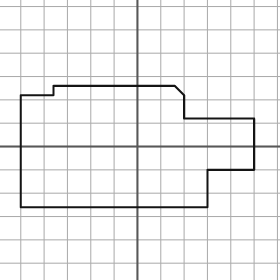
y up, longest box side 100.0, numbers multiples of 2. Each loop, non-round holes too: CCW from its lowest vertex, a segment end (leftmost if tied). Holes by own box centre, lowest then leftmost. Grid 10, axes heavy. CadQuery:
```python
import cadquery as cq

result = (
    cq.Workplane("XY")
    .moveTo(-50.0, -26.0)
    .lineTo(30.0, -26.0)
    .lineTo(30.0, -10.0)
    .lineTo(50.0, -10.0)
    .lineTo(50.0, 12.0)
    .lineTo(20.0, 12.0)
    .lineTo(20.0, 22.0)
    .lineTo(16.0, 26.0)
    .lineTo(-36.0, 26.0)
    .lineTo(-36.0, 22.0)
    .lineTo(-50.0, 22.0)
    .close()
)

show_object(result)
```